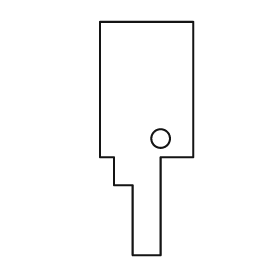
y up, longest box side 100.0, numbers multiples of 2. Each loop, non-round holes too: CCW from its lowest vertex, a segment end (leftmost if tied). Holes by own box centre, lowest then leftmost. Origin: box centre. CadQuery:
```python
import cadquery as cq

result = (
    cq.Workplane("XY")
    .moveTo(-6.0, -50.0)
    .lineTo(6.0, -50.0)
    .lineTo(6.0, -8.0)
    .lineTo(20.0, -8.0)
    .lineTo(20.0, 50.0)
    .lineTo(-20.0, 50.0)
    .lineTo(-20.0, -8.0)
    .lineTo(-14.0, -8.0)
    .lineTo(-14.0, -20.0)
    .lineTo(-6.0, -20.0)
    .close()
    .moveTo(6.0, 0.0)
    .circle(4.0)
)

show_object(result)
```